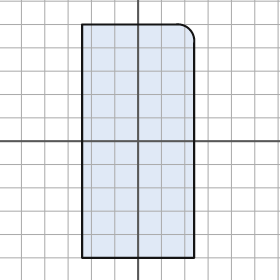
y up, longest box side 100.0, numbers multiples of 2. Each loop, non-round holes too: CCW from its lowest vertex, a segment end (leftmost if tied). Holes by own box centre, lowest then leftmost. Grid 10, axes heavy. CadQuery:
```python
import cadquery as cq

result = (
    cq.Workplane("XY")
    .moveTo(-24.0, -50.0)
    .lineTo(24.0, -50.0)
    .lineTo(24.0, 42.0)
    .threePointArc((22.0, 48.0), (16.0, 50.0))
    .lineTo(-24.0, 50.0)
    .close()
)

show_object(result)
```